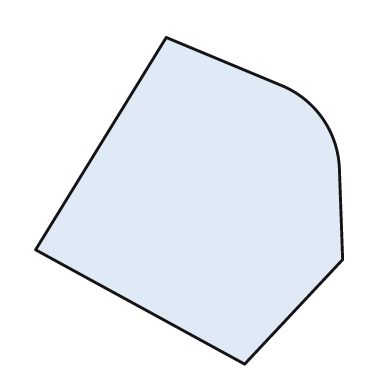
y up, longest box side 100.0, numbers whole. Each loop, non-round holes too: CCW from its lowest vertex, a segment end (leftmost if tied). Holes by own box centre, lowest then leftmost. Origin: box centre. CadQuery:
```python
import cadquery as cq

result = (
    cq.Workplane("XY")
    .moveTo(17.0, -50.0)
    .lineTo(47.0, -18.0)
    .lineTo(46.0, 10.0)
    .threePointArc((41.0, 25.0), (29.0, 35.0))
    .lineTo(-7.0, 50.0)
    .lineTo(-47.0, -15.0)
    .close()
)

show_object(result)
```